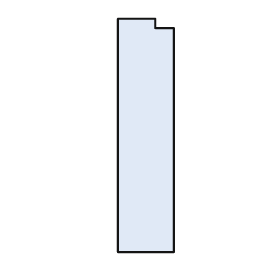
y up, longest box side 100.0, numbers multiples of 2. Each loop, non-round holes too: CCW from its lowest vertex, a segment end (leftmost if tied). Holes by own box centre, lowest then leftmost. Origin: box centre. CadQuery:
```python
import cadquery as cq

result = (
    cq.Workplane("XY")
    .moveTo(-12.0, -50.0)
    .lineTo(12.0, -50.0)
    .lineTo(12.0, 46.0)
    .lineTo(4.0, 46.0)
    .lineTo(4.0, 50.0)
    .lineTo(-12.0, 50.0)
    .close()
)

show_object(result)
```